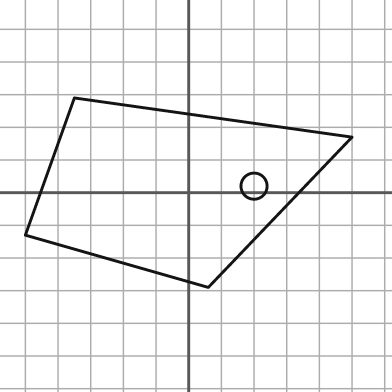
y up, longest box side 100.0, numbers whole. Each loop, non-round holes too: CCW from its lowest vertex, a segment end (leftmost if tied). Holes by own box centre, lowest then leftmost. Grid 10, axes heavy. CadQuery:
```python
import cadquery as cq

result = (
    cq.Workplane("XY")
    .moveTo(6.0, -29.0)
    .lineTo(50.0, 17.0)
    .lineTo(-35.0, 29.0)
    .lineTo(-50.0, -13.0)
    .close()
    .moveTo(20.0, 2.0)
    .circle(4.0)
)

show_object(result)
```